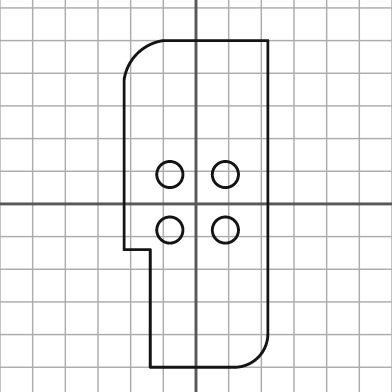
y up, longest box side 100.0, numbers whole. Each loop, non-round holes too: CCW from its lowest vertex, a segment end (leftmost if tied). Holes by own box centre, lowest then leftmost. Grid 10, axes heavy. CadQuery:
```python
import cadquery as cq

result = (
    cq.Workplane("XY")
    .moveTo(-14.0, -50.0)
    .lineTo(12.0, -50.0)
    .threePointArc((19.0, -47.0), (22.0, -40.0))
    .lineTo(22.0, 50.0)
    .lineTo(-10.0, 50.0)
    .threePointArc((-18.0, 46.0), (-22.0, 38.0))
    .lineTo(-22.0, -14.0)
    .lineTo(-14.0, -14.0)
    .close()
    .moveTo(-8.0, -8.0)
    .circle(4.0)
    .moveTo(9.0, -8.0)
    .circle(4.0)
    .moveTo(-8.0, 9.0)
    .circle(4.0)
    .moveTo(9.0, 9.0)
    .circle(4.0)
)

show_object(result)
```